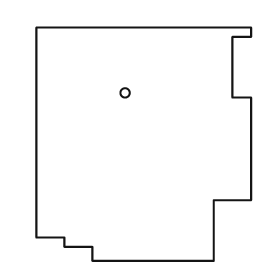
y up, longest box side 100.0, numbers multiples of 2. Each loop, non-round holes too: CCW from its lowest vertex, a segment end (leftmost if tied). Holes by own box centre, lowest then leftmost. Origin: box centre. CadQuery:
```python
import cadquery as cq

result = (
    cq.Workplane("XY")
    .moveTo(-22.0, -50.0)
    .lineTo(30.0, -50.0)
    .lineTo(30.0, -24.0)
    .lineTo(46.0, -24.0)
    .lineTo(46.0, 20.0)
    .lineTo(38.0, 20.0)
    .lineTo(38.0, 46.0)
    .lineTo(46.0, 46.0)
    .lineTo(46.0, 50.0)
    .lineTo(-46.0, 50.0)
    .lineTo(-46.0, -40.0)
    .lineTo(-34.0, -40.0)
    .lineTo(-34.0, -44.0)
    .lineTo(-22.0, -44.0)
    .close()
    .moveTo(-8.0, 22.0)
    .circle(2.0)
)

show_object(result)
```